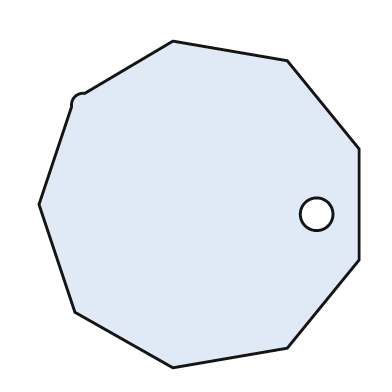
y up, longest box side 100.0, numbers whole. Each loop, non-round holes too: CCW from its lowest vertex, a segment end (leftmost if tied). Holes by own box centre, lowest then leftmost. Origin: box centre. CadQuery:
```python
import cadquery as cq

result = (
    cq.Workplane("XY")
    .moveTo(-8.0, -50.0)
    .lineTo(27.0, -44.0)
    .lineTo(49.0, -17.0)
    .lineTo(49.0, 17.0)
    .lineTo(27.0, 44.0)
    .lineTo(-8.0, 50.0)
    .lineTo(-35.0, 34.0)
    .threePointArc((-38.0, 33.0), (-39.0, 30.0))
    .lineTo(-49.0, 0.0)
    .lineTo(-38.0, -33.0)
    .close()
    .moveTo(36.0, -3.0)
    .circle(5.0)
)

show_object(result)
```